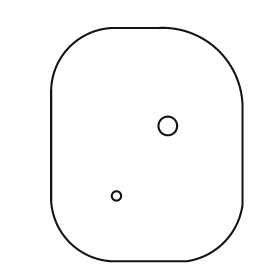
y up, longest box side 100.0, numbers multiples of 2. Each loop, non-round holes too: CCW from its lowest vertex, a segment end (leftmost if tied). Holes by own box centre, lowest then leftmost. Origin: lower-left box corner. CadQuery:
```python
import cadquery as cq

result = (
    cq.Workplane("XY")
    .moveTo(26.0, 0.0)
    .lineTo(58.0, 0.0)
    .threePointArc((74.0, 8.0), (82.0, 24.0))
    .lineTo(82.0, 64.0)
    .threePointArc((72.0, 90.0), (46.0, 100.0))
    .lineTo(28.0, 100.0)
    .threePointArc((8.0, 92.0), (0.0, 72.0))
    .lineTo(0.0, 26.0)
    .threePointArc((8.0, 8.0), (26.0, 0.0))
    .close()
    .moveTo(28.0, 28.0)
    .circle(2.0)
    .moveTo(50.0, 58.0)
    .circle(4.0)
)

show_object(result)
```